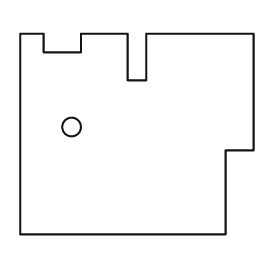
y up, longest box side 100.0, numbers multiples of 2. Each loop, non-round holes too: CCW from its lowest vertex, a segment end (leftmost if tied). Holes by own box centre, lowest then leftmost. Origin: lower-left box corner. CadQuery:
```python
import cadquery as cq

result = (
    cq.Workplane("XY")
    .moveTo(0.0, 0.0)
    .lineTo(88.0, 0.0)
    .lineTo(88.0, 36.0)
    .lineTo(100.0, 36.0)
    .lineTo(100.0, 86.0)
    .lineTo(54.0, 86.0)
    .lineTo(54.0, 66.0)
    .lineTo(46.0, 66.0)
    .lineTo(46.0, 86.0)
    .lineTo(26.0, 86.0)
    .lineTo(26.0, 78.0)
    .lineTo(10.0, 78.0)
    .lineTo(10.0, 86.0)
    .lineTo(0.0, 86.0)
    .close()
    .moveTo(22.0, 46.0)
    .circle(4.0)
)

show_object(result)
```